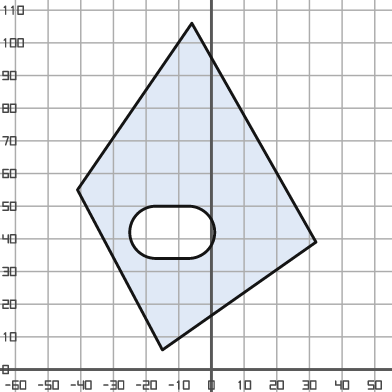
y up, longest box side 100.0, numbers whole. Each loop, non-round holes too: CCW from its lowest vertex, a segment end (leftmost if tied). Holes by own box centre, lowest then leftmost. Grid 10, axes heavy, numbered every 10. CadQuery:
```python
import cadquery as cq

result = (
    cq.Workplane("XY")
    .moveTo(-15.0, 6.0)
    .lineTo(32.0, 39.0)
    .lineTo(-6.0, 106.0)
    .lineTo(-41.0, 55.0)
    .close()
    .moveTo(-17.0, 34.0)
    .lineTo(-7.0, 34.0)
    .threePointArc((1.0, 42.0), (-7.0, 50.0))
    .lineTo(-17.0, 50.0)
    .threePointArc((-25.0, 42.0), (-17.0, 34.0))
    .close()
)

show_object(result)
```